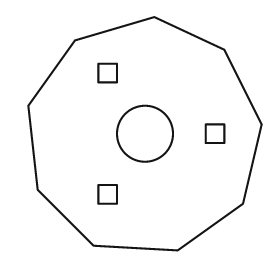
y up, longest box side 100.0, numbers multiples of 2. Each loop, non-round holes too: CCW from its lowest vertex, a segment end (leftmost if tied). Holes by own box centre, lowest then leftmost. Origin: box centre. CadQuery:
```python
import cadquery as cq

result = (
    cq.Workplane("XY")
    .moveTo(14.0, -50.0)
    .lineTo(42.0, -30.0)
    .lineTo(50.0, 4.0)
    .lineTo(34.0, 36.0)
    .lineTo(4.0, 50.0)
    .lineTo(-30.0, 40.0)
    .lineTo(-50.0, 12.0)
    .lineTo(-46.0, -24.0)
    .lineTo(-22.0, -48.0)
    .close()
    .moveTo(-20.0, -30.0)
    .lineTo(-12.0, -30.0)
    .lineTo(-12.0, -22.0)
    .lineTo(-20.0, -22.0)
    .close()
    .moveTo(0.0, 0.0)
    .circle(12.0)
    .moveTo(26.0, -4.0)
    .lineTo(34.0, -4.0)
    .lineTo(34.0, 4.0)
    .lineTo(26.0, 4.0)
    .close()
    .moveTo(-20.0, 22.0)
    .lineTo(-12.0, 22.0)
    .lineTo(-12.0, 30.0)
    .lineTo(-20.0, 30.0)
    .close()
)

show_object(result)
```